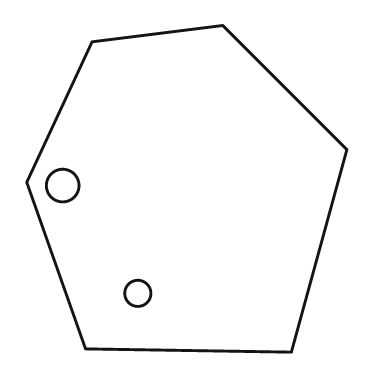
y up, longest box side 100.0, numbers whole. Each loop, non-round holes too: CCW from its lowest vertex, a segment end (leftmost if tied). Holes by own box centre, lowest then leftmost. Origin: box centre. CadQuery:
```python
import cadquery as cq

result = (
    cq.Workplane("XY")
    .moveTo(32.0, -50.0)
    .lineTo(49.0, 12.0)
    .lineTo(11.0, 50.0)
    .lineTo(-29.0, 45.0)
    .lineTo(-49.0, 2.0)
    .lineTo(-31.0, -49.0)
    .close()
    .moveTo(-15.0, -32.0)
    .circle(4.0)
    .moveTo(-38.0, 1.0)
    .circle(5.0)
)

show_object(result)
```